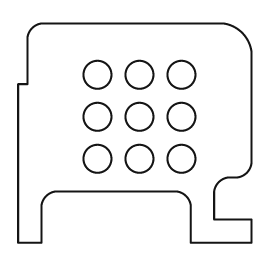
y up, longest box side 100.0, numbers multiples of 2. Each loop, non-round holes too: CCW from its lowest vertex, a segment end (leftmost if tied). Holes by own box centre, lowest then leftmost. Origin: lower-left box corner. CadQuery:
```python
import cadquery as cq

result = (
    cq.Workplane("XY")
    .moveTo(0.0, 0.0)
    .lineTo(10.0, 0.0)
    .lineTo(10.0, 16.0)
    .threePointArc((12.0, 20.0), (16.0, 22.0))
    .lineTo(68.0, 22.0)
    .threePointArc((72.0, 20.0), (74.0, 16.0))
    .lineTo(74.0, 0.0)
    .lineTo(100.0, 0.0)
    .lineTo(100.0, 10.0)
    .lineTo(84.0, 10.0)
    .lineTo(84.0, 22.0)
    .threePointArc((86.0, 26.0), (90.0, 28.0))
    .lineTo(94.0, 28.0)
    .threePointArc((98.0, 30.0), (100.0, 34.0))
    .lineTo(100.0, 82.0)
    .threePointArc((96.0, 90.0), (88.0, 94.0))
    .lineTo(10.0, 94.0)
    .threePointArc((6.0, 92.0), (4.0, 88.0))
    .lineTo(4.0, 68.0)
    .lineTo(0.0, 68.0)
    .close()
    .moveTo(34.0, 36.0)
    .circle(6.0)
    .moveTo(52.0, 36.0)
    .circle(6.0)
    .moveTo(70.0, 36.0)
    .circle(6.0)
    .moveTo(34.0, 54.0)
    .circle(6.0)
    .moveTo(52.0, 54.0)
    .circle(6.0)
    .moveTo(70.0, 54.0)
    .circle(6.0)
    .moveTo(34.0, 72.0)
    .circle(6.0)
    .moveTo(52.0, 72.0)
    .circle(6.0)
    .moveTo(70.0, 72.0)
    .circle(6.0)
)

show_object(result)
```